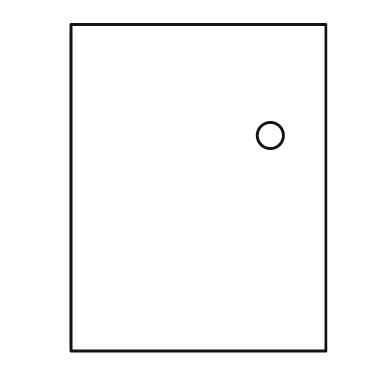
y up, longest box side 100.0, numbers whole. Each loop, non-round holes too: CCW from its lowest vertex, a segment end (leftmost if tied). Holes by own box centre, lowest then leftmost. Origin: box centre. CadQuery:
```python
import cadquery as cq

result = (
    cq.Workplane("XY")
    .moveTo(-39.0, -50.0)
    .lineTo(39.0, -50.0)
    .lineTo(39.0, 50.0)
    .lineTo(-39.0, 50.0)
    .close()
    .moveTo(22.0, 16.0)
    .circle(4.0)
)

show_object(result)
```